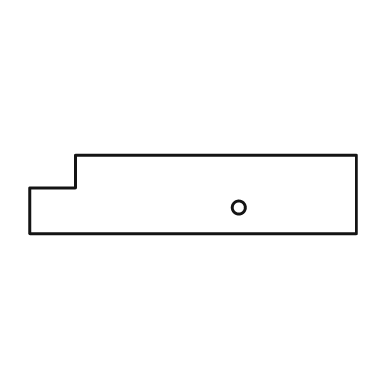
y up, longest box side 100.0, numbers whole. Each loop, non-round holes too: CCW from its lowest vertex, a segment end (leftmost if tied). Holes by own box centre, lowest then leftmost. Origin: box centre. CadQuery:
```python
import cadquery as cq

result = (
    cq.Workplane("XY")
    .moveTo(-50.0, -12.0)
    .lineTo(50.0, -12.0)
    .lineTo(50.0, 12.0)
    .lineTo(-36.0, 12.0)
    .lineTo(-36.0, 2.0)
    .lineTo(-50.0, 2.0)
    .close()
    .moveTo(14.0, -4.0)
    .circle(2.0)
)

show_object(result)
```